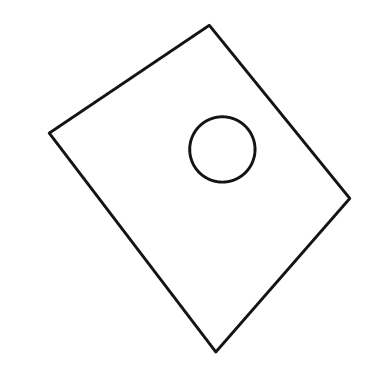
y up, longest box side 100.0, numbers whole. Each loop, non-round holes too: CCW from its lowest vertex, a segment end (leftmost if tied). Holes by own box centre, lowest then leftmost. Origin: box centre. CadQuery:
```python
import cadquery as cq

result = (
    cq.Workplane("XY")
    .moveTo(5.0, -50.0)
    .lineTo(46.0, -3.0)
    .lineTo(3.0, 50.0)
    .lineTo(-46.0, 17.0)
    .close()
    .moveTo(7.0, 12.0)
    .circle(10.0)
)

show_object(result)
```